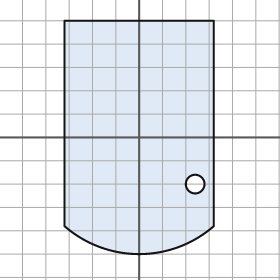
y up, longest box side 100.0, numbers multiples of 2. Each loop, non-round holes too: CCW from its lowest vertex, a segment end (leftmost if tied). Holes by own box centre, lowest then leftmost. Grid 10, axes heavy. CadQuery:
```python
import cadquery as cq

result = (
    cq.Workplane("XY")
    .moveTo(-32.0, -38.0)
    .threePointArc((0.0, -50.0), (32.0, -38.0))
    .lineTo(32.0, 50.0)
    .lineTo(-32.0, 50.0)
    .close()
    .moveTo(24.0, -20.0)
    .circle(4.0)
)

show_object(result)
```